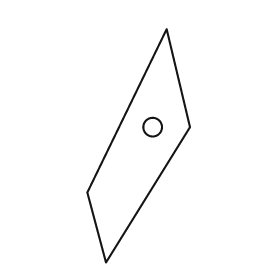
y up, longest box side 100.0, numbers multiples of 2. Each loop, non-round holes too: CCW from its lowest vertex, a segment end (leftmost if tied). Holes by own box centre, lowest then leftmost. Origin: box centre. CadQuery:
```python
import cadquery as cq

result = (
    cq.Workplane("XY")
    .moveTo(-14.0, -50.0)
    .lineTo(22.0, 8.0)
    .lineTo(12.0, 50.0)
    .lineTo(-22.0, -20.0)
    .close()
    .moveTo(6.0, 8.0)
    .circle(4.0)
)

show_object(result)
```